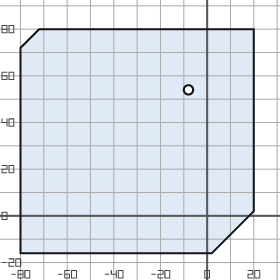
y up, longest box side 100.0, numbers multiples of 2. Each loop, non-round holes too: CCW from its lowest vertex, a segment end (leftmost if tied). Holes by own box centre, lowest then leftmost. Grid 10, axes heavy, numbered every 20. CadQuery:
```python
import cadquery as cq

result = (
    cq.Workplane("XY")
    .moveTo(-80.0, -16.0)
    .lineTo(2.0, -16.0)
    .lineTo(20.0, 2.0)
    .lineTo(20.0, 80.0)
    .lineTo(-72.0, 80.0)
    .lineTo(-80.0, 72.0)
    .close()
    .moveTo(-8.0, 54.0)
    .circle(2.0)
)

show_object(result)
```